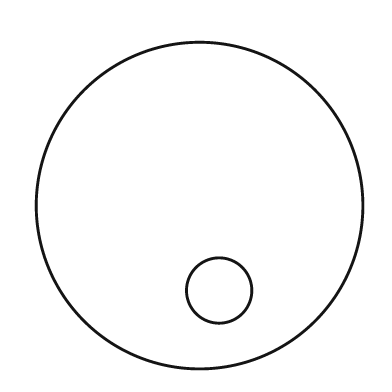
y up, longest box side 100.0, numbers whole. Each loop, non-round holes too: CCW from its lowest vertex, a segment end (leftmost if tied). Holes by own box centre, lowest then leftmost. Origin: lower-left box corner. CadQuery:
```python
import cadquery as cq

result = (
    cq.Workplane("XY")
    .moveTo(50.0, 50.0)
    .circle(50.0)
    .moveTo(56.0, 24.0)
    .circle(10.0)
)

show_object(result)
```